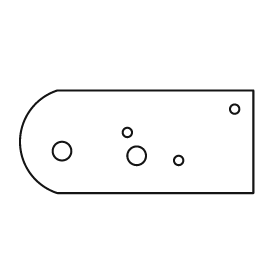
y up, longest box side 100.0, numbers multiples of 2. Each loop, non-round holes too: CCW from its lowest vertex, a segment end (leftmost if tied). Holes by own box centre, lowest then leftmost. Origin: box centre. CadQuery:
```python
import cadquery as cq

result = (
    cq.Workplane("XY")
    .moveTo(-34.0, -22.0)
    .lineTo(50.0, -22.0)
    .lineTo(50.0, 22.0)
    .lineTo(-34.0, 22.0)
    .threePointArc((-50.0, 0.0), (-34.0, -22.0))
    .close()
    .moveTo(18.0, -8.0)
    .circle(2.0)
    .moveTo(0.0, -6.0)
    .circle(4.0)
    .moveTo(-32.0, -4.0)
    .circle(4.0)
    .moveTo(-4.0, 4.0)
    .circle(2.0)
    .moveTo(42.0, 14.0)
    .circle(2.0)
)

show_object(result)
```